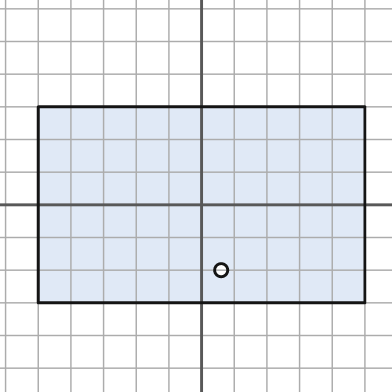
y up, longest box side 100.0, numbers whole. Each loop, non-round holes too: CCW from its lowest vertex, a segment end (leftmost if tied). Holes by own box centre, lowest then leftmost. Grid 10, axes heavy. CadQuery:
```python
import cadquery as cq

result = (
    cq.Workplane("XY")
    .moveTo(-50.0, -30.0)
    .lineTo(50.0, -30.0)
    .lineTo(50.0, 30.0)
    .lineTo(-50.0, 30.0)
    .close()
    .moveTo(6.0, -20.0)
    .circle(2.0)
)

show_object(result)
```